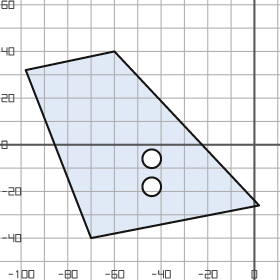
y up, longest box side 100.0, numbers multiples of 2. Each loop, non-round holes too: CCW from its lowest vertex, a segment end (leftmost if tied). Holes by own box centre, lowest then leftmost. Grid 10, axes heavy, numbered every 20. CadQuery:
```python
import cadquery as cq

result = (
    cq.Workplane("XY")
    .moveTo(-70.0, -40.0)
    .lineTo(2.0, -26.0)
    .lineTo(-60.0, 40.0)
    .lineTo(-98.0, 32.0)
    .close()
    .moveTo(-44.0, -18.0)
    .circle(4.0)
    .moveTo(-44.0, -6.0)
    .circle(4.0)
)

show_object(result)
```